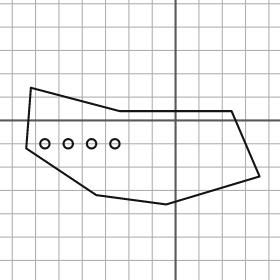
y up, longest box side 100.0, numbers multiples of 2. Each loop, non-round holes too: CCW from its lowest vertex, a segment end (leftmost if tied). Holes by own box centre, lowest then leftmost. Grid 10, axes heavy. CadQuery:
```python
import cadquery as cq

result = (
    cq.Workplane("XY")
    .moveTo(-4.0, -36.0)
    .lineTo(36.0, -24.0)
    .lineTo(24.0, 4.0)
    .lineTo(-24.0, 4.0)
    .lineTo(-62.0, 14.0)
    .lineTo(-64.0, -12.0)
    .lineTo(-34.0, -32.0)
    .close()
    .moveTo(-56.0, -10.0)
    .circle(2.0)
    .moveTo(-46.0, -10.0)
    .circle(2.0)
    .moveTo(-36.0, -10.0)
    .circle(2.0)
    .moveTo(-26.0, -10.0)
    .circle(2.0)
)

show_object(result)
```